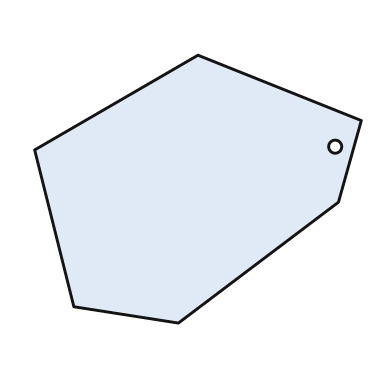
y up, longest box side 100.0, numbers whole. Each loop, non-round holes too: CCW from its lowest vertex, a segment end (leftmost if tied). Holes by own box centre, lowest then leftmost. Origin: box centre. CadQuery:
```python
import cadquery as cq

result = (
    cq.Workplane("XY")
    .moveTo(-6.0, -41.0)
    .lineTo(43.0, -4.0)
    .lineTo(50.0, 21.0)
    .lineTo(0.0, 41.0)
    .lineTo(-50.0, 12.0)
    .lineTo(-38.0, -36.0)
    .close()
    .moveTo(42.0, 13.0)
    .circle(2.0)
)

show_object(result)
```